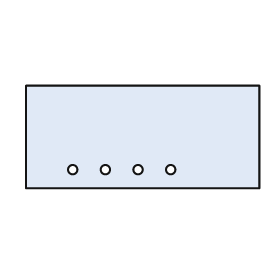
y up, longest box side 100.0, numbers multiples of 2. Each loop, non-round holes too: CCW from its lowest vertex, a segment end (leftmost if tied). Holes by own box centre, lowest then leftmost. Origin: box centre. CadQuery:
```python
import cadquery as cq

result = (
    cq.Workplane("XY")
    .moveTo(-50.0, -22.0)
    .lineTo(50.0, -22.0)
    .lineTo(50.0, 22.0)
    .lineTo(-50.0, 22.0)
    .close()
    .moveTo(-30.0, -14.0)
    .circle(2.0)
    .moveTo(-16.0, -14.0)
    .circle(2.0)
    .moveTo(-2.0, -14.0)
    .circle(2.0)
    .moveTo(12.0, -14.0)
    .circle(2.0)
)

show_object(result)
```